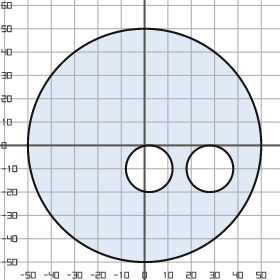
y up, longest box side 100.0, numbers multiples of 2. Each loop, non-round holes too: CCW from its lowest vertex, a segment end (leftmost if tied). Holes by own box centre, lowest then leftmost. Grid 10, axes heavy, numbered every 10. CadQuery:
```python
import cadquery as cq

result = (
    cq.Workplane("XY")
    .moveTo(0.0, 0.0)
    .circle(50.0)
    .moveTo(2.0, -10.0)
    .circle(10.0)
    .moveTo(28.0, -10.0)
    .circle(10.0)
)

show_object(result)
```